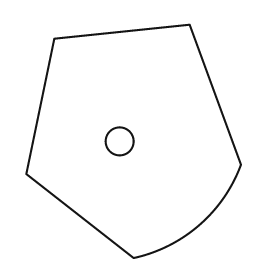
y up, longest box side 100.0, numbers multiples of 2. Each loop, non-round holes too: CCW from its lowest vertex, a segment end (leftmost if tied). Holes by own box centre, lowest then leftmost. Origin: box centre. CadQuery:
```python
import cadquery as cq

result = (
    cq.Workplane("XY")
    .moveTo(0.0, -50.0)
    .threePointArc((28.0, -36.0), (46.0, -10.0))
    .lineTo(24.0, 50.0)
    .lineTo(-34.0, 44.0)
    .lineTo(-46.0, -14.0)
    .close()
    .moveTo(-6.0, 0.0)
    .circle(6.0)
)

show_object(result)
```